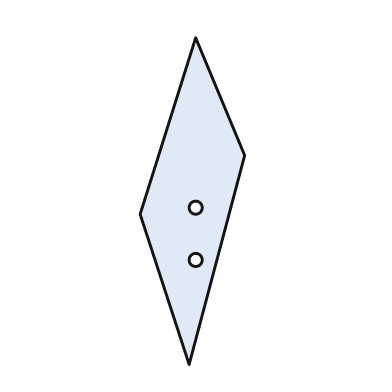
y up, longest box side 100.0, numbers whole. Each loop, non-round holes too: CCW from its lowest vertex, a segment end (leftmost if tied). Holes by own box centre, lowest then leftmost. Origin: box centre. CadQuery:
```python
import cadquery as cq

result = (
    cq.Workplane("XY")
    .moveTo(-1.0, -50.0)
    .lineTo(16.0, 14.0)
    .lineTo(1.0, 50.0)
    .lineTo(-16.0, -4.0)
    .close()
    .moveTo(1.0, -18.0)
    .circle(2.0)
    .moveTo(1.0, -2.0)
    .circle(2.0)
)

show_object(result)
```